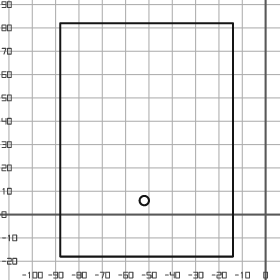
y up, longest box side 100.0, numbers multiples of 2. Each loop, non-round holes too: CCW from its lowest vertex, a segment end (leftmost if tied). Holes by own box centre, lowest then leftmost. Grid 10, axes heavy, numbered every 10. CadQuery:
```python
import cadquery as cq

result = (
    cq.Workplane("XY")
    .moveTo(-88.0, -18.0)
    .lineTo(-14.0, -18.0)
    .lineTo(-14.0, 82.0)
    .lineTo(-88.0, 82.0)
    .close()
    .moveTo(-52.0, 6.0)
    .circle(2.0)
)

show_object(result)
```